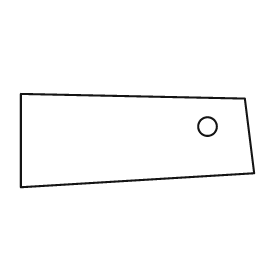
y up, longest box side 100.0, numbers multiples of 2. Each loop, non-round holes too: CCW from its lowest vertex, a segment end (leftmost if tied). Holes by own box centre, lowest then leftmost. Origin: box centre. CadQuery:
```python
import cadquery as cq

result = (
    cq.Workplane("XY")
    .moveTo(-50.0, -20.0)
    .lineTo(50.0, -14.0)
    .lineTo(46.0, 18.0)
    .lineTo(-50.0, 20.0)
    .close()
    .moveTo(30.0, 6.0)
    .circle(4.0)
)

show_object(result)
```